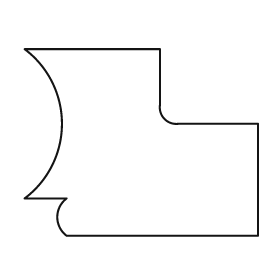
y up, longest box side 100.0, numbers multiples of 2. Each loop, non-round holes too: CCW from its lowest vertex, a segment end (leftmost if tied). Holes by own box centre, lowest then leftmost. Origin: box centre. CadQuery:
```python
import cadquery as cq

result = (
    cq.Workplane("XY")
    .moveTo(-32.0, -40.0)
    .lineTo(50.0, -40.0)
    .lineTo(50.0, 8.0)
    .lineTo(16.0, 8.0)
    .threePointArc((10.0, 10.0), (8.0, 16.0))
    .lineTo(8.0, 40.0)
    .lineTo(-50.0, 40.0)
    .threePointArc((-34.0, 8.0), (-50.0, -24.0))
    .lineTo(-32.0, -24.0)
    .threePointArc((-36.0, -32.0), (-32.0, -40.0))
    .close()
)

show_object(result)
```